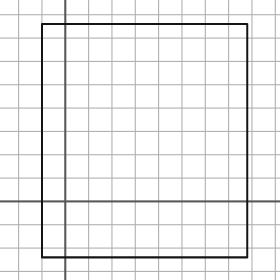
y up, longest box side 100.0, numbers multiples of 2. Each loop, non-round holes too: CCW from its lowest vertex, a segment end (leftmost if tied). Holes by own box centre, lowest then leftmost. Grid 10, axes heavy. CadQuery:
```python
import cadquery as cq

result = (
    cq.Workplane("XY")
    .moveTo(-10.0, -24.0)
    .lineTo(78.0, -24.0)
    .lineTo(78.0, 76.0)
    .lineTo(-10.0, 76.0)
    .close()
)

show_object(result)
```